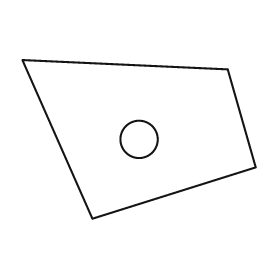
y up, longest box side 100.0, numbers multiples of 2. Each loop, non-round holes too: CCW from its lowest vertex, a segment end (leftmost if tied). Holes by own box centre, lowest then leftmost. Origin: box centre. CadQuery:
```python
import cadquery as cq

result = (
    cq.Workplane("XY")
    .moveTo(-20.0, -34.0)
    .lineTo(50.0, -12.0)
    .lineTo(38.0, 30.0)
    .lineTo(-50.0, 34.0)
    .close()
    .moveTo(0.0, 0.0)
    .circle(8.0)
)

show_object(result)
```